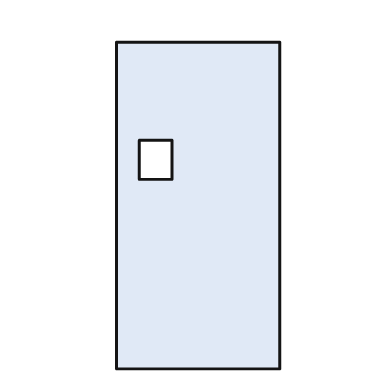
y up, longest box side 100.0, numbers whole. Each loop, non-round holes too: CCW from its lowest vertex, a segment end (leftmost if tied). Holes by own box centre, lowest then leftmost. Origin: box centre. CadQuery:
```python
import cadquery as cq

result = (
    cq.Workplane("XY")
    .moveTo(-25.0, -50.0)
    .lineTo(25.0, -50.0)
    .lineTo(25.0, 50.0)
    .lineTo(-25.0, 50.0)
    .close()
    .moveTo(-18.0, 8.0)
    .lineTo(-8.0, 8.0)
    .lineTo(-8.0, 20.0)
    .lineTo(-18.0, 20.0)
    .close()
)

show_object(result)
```